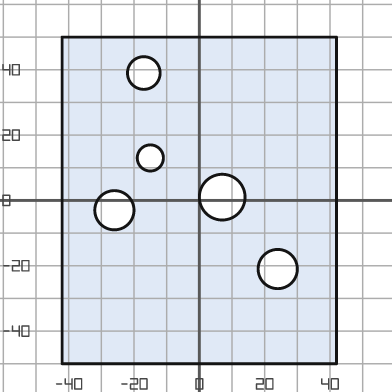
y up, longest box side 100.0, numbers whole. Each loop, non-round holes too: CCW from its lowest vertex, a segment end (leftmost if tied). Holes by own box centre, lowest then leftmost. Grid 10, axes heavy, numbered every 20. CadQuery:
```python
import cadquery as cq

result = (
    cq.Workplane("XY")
    .moveTo(-42.0, -50.0)
    .lineTo(42.0, -50.0)
    .lineTo(42.0, 50.0)
    .lineTo(-42.0, 50.0)
    .close()
    .moveTo(24.0, -21.0)
    .circle(6.0)
    .moveTo(-26.0, -3.0)
    .circle(6.0)
    .moveTo(7.0, 1.0)
    .circle(7.0)
    .moveTo(-15.0, 13.0)
    .circle(4.0)
    .moveTo(-17.0, 39.0)
    .circle(5.0)
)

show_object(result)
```